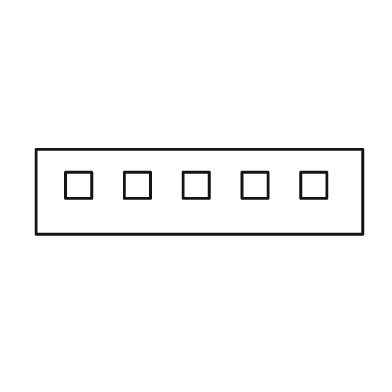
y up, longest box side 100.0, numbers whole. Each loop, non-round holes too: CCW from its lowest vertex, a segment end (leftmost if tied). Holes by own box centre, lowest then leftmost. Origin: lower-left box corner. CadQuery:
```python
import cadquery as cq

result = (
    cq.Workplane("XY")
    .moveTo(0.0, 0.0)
    .lineTo(100.0, 0.0)
    .lineTo(100.0, 26.0)
    .lineTo(0.0, 26.0)
    .close()
    .moveTo(9.0, 11.0)
    .lineTo(17.0, 11.0)
    .lineTo(17.0, 19.0)
    .lineTo(9.0, 19.0)
    .close()
    .moveTo(27.0, 11.0)
    .lineTo(35.0, 11.0)
    .lineTo(35.0, 19.0)
    .lineTo(27.0, 19.0)
    .close()
    .moveTo(45.0, 11.0)
    .lineTo(53.0, 11.0)
    .lineTo(53.0, 19.0)
    .lineTo(45.0, 19.0)
    .close()
    .moveTo(63.0, 11.0)
    .lineTo(71.0, 11.0)
    .lineTo(71.0, 19.0)
    .lineTo(63.0, 19.0)
    .close()
    .moveTo(81.0, 11.0)
    .lineTo(89.0, 11.0)
    .lineTo(89.0, 19.0)
    .lineTo(81.0, 19.0)
    .close()
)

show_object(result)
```